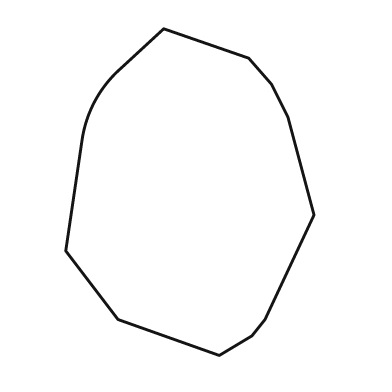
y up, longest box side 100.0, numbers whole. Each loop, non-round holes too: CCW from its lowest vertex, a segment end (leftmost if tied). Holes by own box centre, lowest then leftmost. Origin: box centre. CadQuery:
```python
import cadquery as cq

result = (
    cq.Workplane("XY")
    .moveTo(9.0, -50.0)
    .lineTo(19.0, -44.0)
    .lineTo(23.0, -39.0)
    .lineTo(38.0, -7.0)
    .lineTo(30.0, 23.0)
    .lineTo(25.0, 33.0)
    .lineTo(18.0, 41.0)
    .lineTo(-8.0, 50.0)
    .lineTo(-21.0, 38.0)
    .threePointArc((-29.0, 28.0), (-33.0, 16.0))
    .lineTo(-38.0, -18.0)
    .lineTo(-22.0, -39.0)
    .close()
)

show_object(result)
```